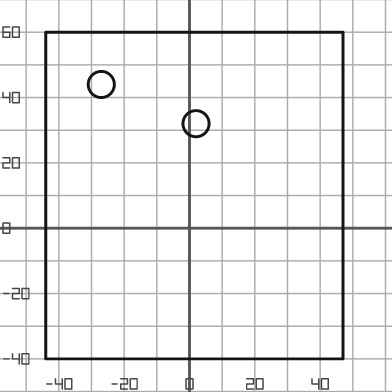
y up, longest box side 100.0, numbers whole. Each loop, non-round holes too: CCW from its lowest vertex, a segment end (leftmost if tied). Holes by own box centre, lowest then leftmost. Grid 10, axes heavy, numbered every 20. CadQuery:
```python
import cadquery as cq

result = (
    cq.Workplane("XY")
    .moveTo(-44.0, -40.0)
    .lineTo(47.0, -40.0)
    .lineTo(47.0, 60.0)
    .lineTo(-44.0, 60.0)
    .close()
    .moveTo(2.0, 32.0)
    .circle(4.0)
    .moveTo(-27.0, 44.0)
    .circle(4.0)
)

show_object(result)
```